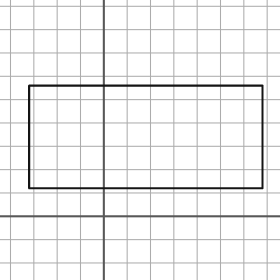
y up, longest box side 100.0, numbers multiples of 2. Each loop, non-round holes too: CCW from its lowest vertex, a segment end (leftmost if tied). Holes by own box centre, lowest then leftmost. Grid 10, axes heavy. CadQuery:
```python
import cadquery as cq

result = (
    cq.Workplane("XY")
    .moveTo(-32.0, 12.0)
    .lineTo(68.0, 12.0)
    .lineTo(68.0, 56.0)
    .lineTo(-32.0, 56.0)
    .close()
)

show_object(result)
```